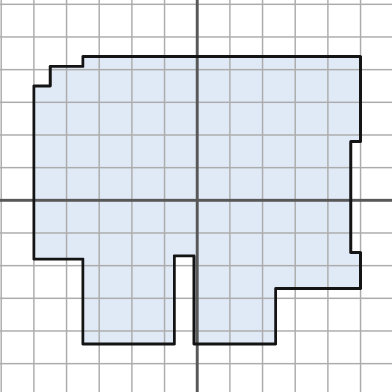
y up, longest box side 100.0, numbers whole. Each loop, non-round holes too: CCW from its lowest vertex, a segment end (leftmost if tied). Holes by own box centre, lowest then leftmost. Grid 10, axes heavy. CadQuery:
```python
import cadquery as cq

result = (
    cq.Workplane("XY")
    .moveTo(-35.0, -44.0)
    .lineTo(-7.0, -44.0)
    .lineTo(-7.0, -17.0)
    .lineTo(-1.0, -17.0)
    .lineTo(-1.0, -44.0)
    .lineTo(24.0, -44.0)
    .lineTo(24.0, -27.0)
    .lineTo(50.0, -27.0)
    .lineTo(50.0, -16.0)
    .lineTo(47.0, -16.0)
    .lineTo(47.0, 18.0)
    .lineTo(50.0, 18.0)
    .lineTo(50.0, 44.0)
    .lineTo(-35.0, 44.0)
    .lineTo(-35.0, 41.0)
    .lineTo(-45.0, 41.0)
    .lineTo(-45.0, 35.0)
    .lineTo(-50.0, 35.0)
    .lineTo(-50.0, -18.0)
    .lineTo(-35.0, -18.0)
    .close()
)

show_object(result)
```